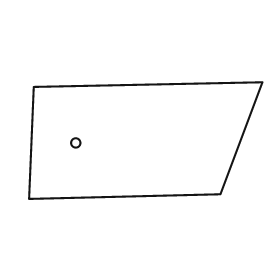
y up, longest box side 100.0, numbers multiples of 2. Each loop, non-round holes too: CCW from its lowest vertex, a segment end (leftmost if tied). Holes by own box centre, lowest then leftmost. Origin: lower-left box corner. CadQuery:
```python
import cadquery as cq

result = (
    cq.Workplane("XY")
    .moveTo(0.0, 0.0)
    .lineTo(82.0, 2.0)
    .lineTo(100.0, 50.0)
    .lineTo(2.0, 48.0)
    .close()
    .moveTo(20.0, 24.0)
    .circle(2.0)
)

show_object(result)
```